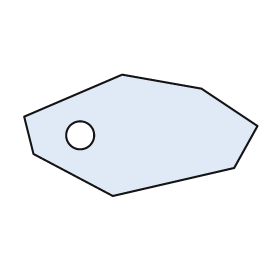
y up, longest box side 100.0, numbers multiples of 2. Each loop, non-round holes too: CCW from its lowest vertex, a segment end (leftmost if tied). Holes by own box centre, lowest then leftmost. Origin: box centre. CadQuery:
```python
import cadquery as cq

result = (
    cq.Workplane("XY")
    .moveTo(-12.0, -26.0)
    .lineTo(40.0, -14.0)
    .lineTo(50.0, 4.0)
    .lineTo(26.0, 20.0)
    .lineTo(-8.0, 26.0)
    .lineTo(-50.0, 8.0)
    .lineTo(-46.0, -8.0)
    .close()
    .moveTo(-26.0, 0.0)
    .circle(6.0)
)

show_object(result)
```